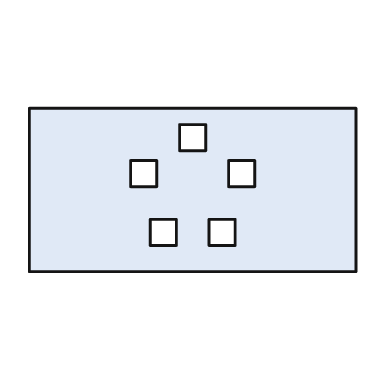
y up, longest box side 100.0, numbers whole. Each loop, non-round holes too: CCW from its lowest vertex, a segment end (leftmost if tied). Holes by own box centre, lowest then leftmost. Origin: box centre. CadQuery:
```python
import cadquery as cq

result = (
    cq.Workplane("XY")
    .moveTo(-50.0, -25.0)
    .lineTo(50.0, -25.0)
    .lineTo(50.0, 25.0)
    .lineTo(-50.0, 25.0)
    .close()
    .moveTo(-13.0, -17.0)
    .lineTo(-5.0, -17.0)
    .lineTo(-5.0, -9.0)
    .lineTo(-13.0, -9.0)
    .close()
    .moveTo(5.0, -17.0)
    .lineTo(13.0, -17.0)
    .lineTo(13.0, -9.0)
    .lineTo(5.0, -9.0)
    .close()
    .moveTo(-19.0, 1.0)
    .lineTo(-11.0, 1.0)
    .lineTo(-11.0, 9.0)
    .lineTo(-19.0, 9.0)
    .close()
    .moveTo(11.0, 1.0)
    .lineTo(19.0, 1.0)
    .lineTo(19.0, 9.0)
    .lineTo(11.0, 9.0)
    .close()
    .moveTo(-4.0, 12.0)
    .lineTo(4.0, 12.0)
    .lineTo(4.0, 20.0)
    .lineTo(-4.0, 20.0)
    .close()
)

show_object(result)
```